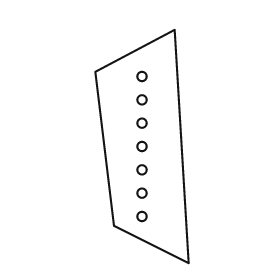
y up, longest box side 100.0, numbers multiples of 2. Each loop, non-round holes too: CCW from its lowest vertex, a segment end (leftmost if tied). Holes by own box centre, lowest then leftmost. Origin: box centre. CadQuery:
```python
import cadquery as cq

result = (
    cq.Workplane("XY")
    .moveTo(20.0, -50.0)
    .lineTo(14.0, 50.0)
    .lineTo(-20.0, 32.0)
    .lineTo(-12.0, -34.0)
    .close()
    .moveTo(0.0, -30.0)
    .circle(2.0)
    .moveTo(0.0, -20.0)
    .circle(2.0)
    .moveTo(0.0, -10.0)
    .circle(2.0)
    .moveTo(0.0, 0.0)
    .circle(2.0)
    .moveTo(0.0, 10.0)
    .circle(2.0)
    .moveTo(0.0, 20.0)
    .circle(2.0)
    .moveTo(0.0, 30.0)
    .circle(2.0)
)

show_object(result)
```